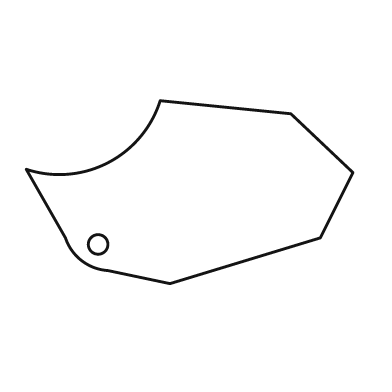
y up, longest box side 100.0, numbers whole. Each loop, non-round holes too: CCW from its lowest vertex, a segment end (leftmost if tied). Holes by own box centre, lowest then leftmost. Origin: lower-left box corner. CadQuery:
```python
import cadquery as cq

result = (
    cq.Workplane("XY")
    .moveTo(44.0, 0.0)
    .lineTo(90.0, 14.0)
    .lineTo(100.0, 34.0)
    .lineTo(81.0, 52.0)
    .lineTo(41.0, 56.0)
    .threePointArc((25.0, 37.0), (0.0, 35.0))
    .lineTo(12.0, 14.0)
    .threePointArc((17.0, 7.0), (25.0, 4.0))
    .close()
    .moveTo(22.0, 12.0)
    .circle(3.0)
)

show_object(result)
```